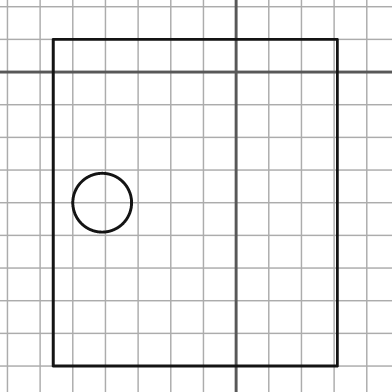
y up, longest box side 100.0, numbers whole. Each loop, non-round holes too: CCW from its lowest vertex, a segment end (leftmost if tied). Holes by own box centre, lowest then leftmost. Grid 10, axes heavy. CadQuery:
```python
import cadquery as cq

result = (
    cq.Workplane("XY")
    .moveTo(-56.0, -90.0)
    .lineTo(31.0, -90.0)
    .lineTo(31.0, 10.0)
    .lineTo(-56.0, 10.0)
    .close()
    .moveTo(-41.0, -40.0)
    .circle(9.0)
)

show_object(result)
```